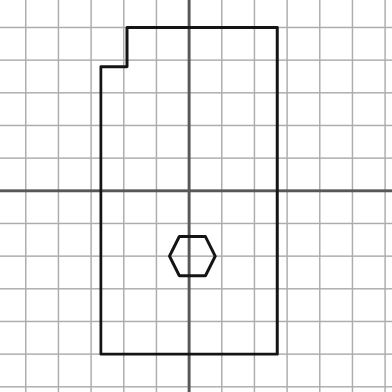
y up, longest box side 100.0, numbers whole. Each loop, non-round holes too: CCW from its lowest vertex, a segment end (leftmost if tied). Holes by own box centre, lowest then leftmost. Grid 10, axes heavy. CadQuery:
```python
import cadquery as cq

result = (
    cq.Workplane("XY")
    .moveTo(-27.0, -50.0)
    .lineTo(27.0, -50.0)
    .lineTo(27.0, 50.0)
    .lineTo(-19.0, 50.0)
    .lineTo(-19.0, 38.0)
    .lineTo(-27.0, 38.0)
    .close()
    .moveTo(-3.0, -26.0)
    .lineTo(5.0, -26.0)
    .lineTo(8.0, -20.0)
    .lineTo(5.0, -14.0)
    .lineTo(-3.0, -14.0)
    .lineTo(-6.0, -20.0)
    .close()
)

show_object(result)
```